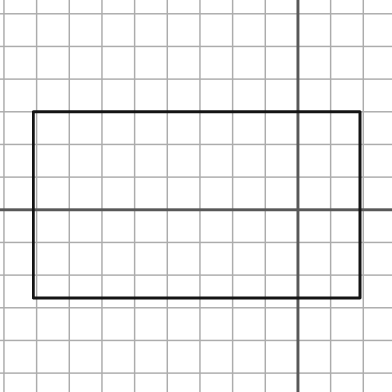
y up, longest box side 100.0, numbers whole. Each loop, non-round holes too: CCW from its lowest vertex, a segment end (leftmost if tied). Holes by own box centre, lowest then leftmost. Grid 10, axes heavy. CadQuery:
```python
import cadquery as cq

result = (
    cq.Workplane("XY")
    .moveTo(-81.0, -27.0)
    .lineTo(19.0, -27.0)
    .lineTo(19.0, 30.0)
    .lineTo(-81.0, 30.0)
    .close()
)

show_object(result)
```